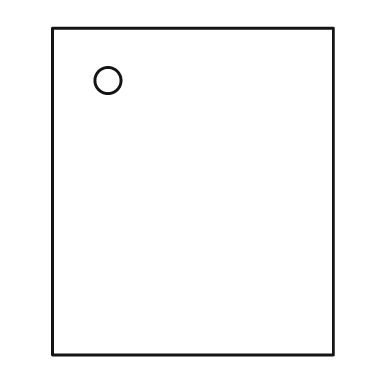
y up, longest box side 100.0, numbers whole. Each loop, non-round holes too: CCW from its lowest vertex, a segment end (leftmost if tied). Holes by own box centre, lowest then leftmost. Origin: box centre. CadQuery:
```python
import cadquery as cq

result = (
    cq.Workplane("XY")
    .moveTo(-43.0, -50.0)
    .lineTo(43.0, -50.0)
    .lineTo(43.0, 50.0)
    .lineTo(-43.0, 50.0)
    .close()
    .moveTo(-26.0, 34.0)
    .circle(4.0)
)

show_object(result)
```